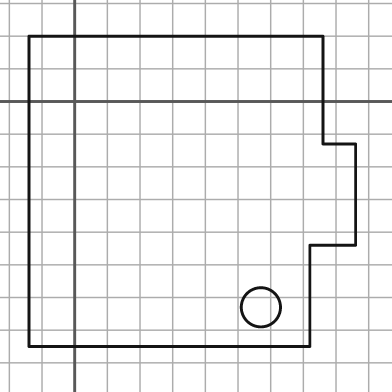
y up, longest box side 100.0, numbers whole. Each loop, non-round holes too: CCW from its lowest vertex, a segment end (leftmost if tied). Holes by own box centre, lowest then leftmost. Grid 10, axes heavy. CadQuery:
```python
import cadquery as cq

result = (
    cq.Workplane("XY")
    .moveTo(-14.0, -75.0)
    .lineTo(72.0, -75.0)
    .lineTo(72.0, -44.0)
    .lineTo(86.0, -44.0)
    .lineTo(86.0, -13.0)
    .lineTo(76.0, -13.0)
    .lineTo(76.0, 20.0)
    .lineTo(-14.0, 20.0)
    .close()
    .moveTo(57.0, -63.0)
    .circle(6.0)
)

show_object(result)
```